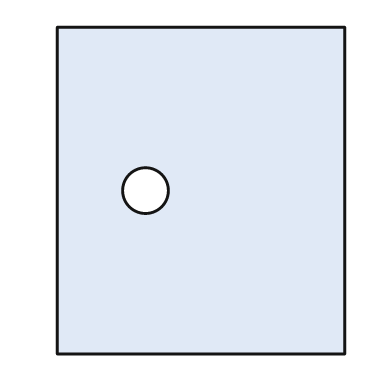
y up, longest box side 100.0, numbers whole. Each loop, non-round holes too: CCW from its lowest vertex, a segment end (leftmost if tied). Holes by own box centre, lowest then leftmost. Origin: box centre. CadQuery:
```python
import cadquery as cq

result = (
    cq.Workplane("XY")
    .moveTo(-44.0, -50.0)
    .lineTo(44.0, -50.0)
    .lineTo(44.0, 50.0)
    .lineTo(-44.0, 50.0)
    .close()
    .moveTo(-17.0, 0.0)
    .circle(7.0)
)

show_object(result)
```